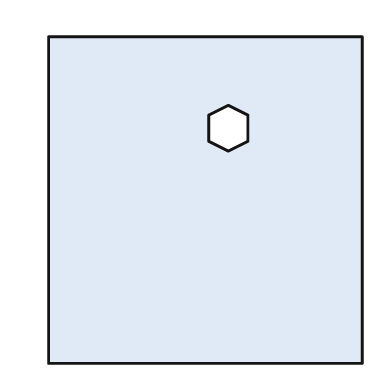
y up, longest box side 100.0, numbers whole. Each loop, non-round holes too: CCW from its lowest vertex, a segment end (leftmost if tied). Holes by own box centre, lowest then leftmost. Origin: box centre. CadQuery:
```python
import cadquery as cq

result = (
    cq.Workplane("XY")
    .moveTo(-48.0, -50.0)
    .lineTo(48.0, -50.0)
    .lineTo(48.0, 50.0)
    .lineTo(-48.0, 50.0)
    .close()
    .moveTo(7.0, 15.0)
    .lineTo(13.0, 18.0)
    .lineTo(13.0, 26.0)
    .lineTo(7.0, 29.0)
    .lineTo(1.0, 26.0)
    .lineTo(1.0, 18.0)
    .close()
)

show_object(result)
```